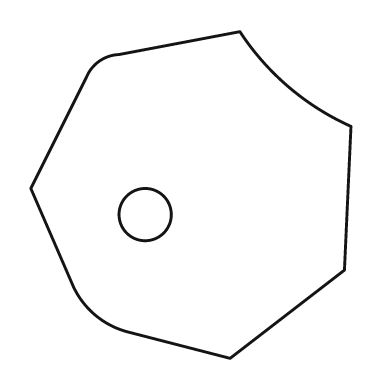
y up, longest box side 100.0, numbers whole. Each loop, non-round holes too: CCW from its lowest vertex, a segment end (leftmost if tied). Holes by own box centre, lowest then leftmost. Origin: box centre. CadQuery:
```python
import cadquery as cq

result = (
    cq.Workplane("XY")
    .moveTo(12.0, -50.0)
    .lineTo(47.0, -23.0)
    .lineTo(49.0, 21.0)
    .threePointArc((30.0, 33.0), (15.0, 50.0))
    .lineTo(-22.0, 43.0)
    .threePointArc((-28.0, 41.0), (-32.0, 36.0))
    .lineTo(-49.0, 2.0)
    .lineTo(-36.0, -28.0)
    .threePointArc((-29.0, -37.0), (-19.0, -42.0))
    .close()
    .moveTo(-14.0, -6.0)
    .circle(8.0)
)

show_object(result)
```